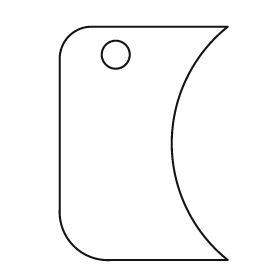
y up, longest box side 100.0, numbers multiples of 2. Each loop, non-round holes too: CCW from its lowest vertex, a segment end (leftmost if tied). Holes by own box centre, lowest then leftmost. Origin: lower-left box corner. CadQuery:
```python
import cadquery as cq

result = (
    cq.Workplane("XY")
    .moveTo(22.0, 0.0)
    .lineTo(72.0, 0.0)
    .threePointArc((48.0, 50.0), (72.0, 100.0))
    .lineTo(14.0, 100.0)
    .threePointArc((4.0, 96.0), (0.0, 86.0))
    .lineTo(0.0, 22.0)
    .threePointArc((6.0, 6.0), (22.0, 0.0))
    .close()
    .moveTo(24.0, 88.0)
    .circle(6.0)
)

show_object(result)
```